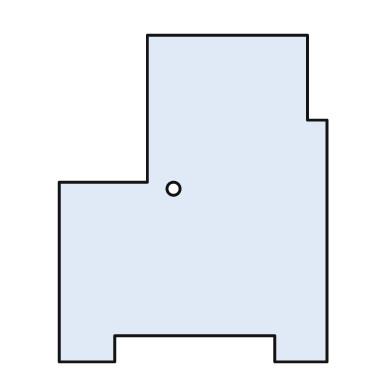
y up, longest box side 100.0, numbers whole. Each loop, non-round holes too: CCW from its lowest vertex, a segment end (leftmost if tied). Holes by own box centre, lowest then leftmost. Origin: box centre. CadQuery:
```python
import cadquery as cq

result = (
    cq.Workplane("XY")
    .moveTo(-41.0, -50.0)
    .lineTo(-24.0, -50.0)
    .lineTo(-24.0, -42.0)
    .lineTo(25.0, -42.0)
    .lineTo(25.0, -50.0)
    .lineTo(41.0, -50.0)
    .lineTo(41.0, 24.0)
    .lineTo(35.0, 24.0)
    .lineTo(35.0, 50.0)
    .lineTo(-14.0, 50.0)
    .lineTo(-14.0, 5.0)
    .lineTo(-41.0, 5.0)
    .close()
    .moveTo(-6.0, 3.0)
    .circle(2.0)
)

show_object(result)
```